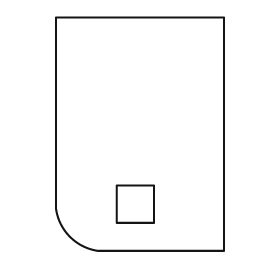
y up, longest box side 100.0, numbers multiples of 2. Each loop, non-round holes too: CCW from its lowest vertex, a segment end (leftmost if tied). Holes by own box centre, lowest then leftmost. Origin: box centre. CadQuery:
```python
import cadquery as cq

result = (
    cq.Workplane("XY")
    .moveTo(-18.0, -50.0)
    .lineTo(36.0, -50.0)
    .lineTo(36.0, 50.0)
    .lineTo(-36.0, 50.0)
    .lineTo(-36.0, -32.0)
    .threePointArc((-30.0, -44.0), (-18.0, -50.0))
    .close()
    .moveTo(-10.0, -38.0)
    .lineTo(6.0, -38.0)
    .lineTo(6.0, -22.0)
    .lineTo(-10.0, -22.0)
    .close()
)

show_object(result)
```